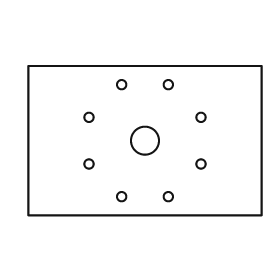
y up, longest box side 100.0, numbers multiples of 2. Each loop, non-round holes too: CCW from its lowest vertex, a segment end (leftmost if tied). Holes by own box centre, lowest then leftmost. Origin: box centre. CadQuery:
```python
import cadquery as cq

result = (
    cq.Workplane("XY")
    .moveTo(-50.0, -32.0)
    .lineTo(50.0, -32.0)
    .lineTo(50.0, 32.0)
    .lineTo(-50.0, 32.0)
    .close()
    .moveTo(-10.0, -24.0)
    .circle(2.0)
    .moveTo(10.0, -24.0)
    .circle(2.0)
    .moveTo(-24.0, -10.0)
    .circle(2.0)
    .moveTo(24.0, -10.0)
    .circle(2.0)
    .moveTo(0.0, 0.0)
    .circle(6.0)
    .moveTo(-24.0, 10.0)
    .circle(2.0)
    .moveTo(24.0, 10.0)
    .circle(2.0)
    .moveTo(-10.0, 24.0)
    .circle(2.0)
    .moveTo(10.0, 24.0)
    .circle(2.0)
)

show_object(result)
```